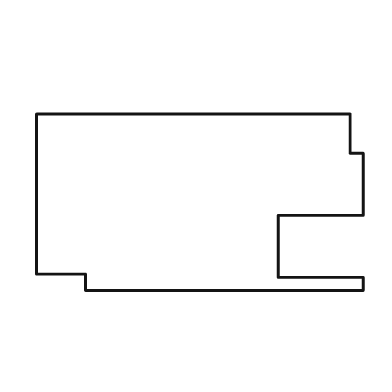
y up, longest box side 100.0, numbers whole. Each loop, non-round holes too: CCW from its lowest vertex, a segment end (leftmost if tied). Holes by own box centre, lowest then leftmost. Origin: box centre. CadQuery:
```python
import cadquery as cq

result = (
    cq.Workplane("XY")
    .moveTo(-35.0, -27.0)
    .lineTo(50.0, -27.0)
    .lineTo(50.0, -23.0)
    .lineTo(24.0, -23.0)
    .lineTo(24.0, -4.0)
    .lineTo(50.0, -4.0)
    .lineTo(50.0, 15.0)
    .lineTo(46.0, 15.0)
    .lineTo(46.0, 27.0)
    .lineTo(-50.0, 27.0)
    .lineTo(-50.0, -22.0)
    .lineTo(-35.0, -22.0)
    .close()
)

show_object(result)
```